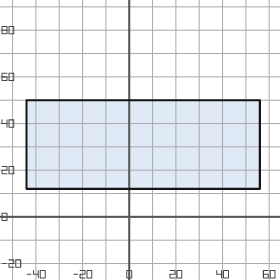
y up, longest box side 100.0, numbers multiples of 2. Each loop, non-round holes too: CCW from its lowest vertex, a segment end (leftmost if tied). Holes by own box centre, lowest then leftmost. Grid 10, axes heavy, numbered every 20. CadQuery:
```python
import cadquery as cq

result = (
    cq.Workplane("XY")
    .moveTo(-44.0, 12.0)
    .lineTo(56.0, 12.0)
    .lineTo(56.0, 50.0)
    .lineTo(-44.0, 50.0)
    .close()
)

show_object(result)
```